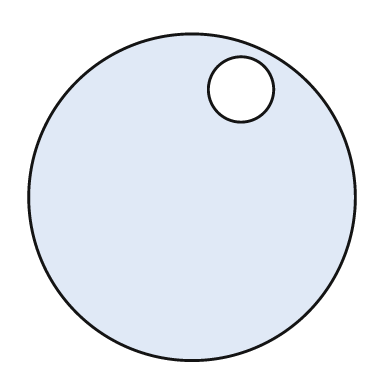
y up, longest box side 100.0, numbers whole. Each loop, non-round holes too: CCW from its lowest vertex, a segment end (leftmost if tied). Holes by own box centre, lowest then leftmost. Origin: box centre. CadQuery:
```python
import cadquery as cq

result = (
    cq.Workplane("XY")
    .moveTo(0.0, 0.0)
    .circle(50.0)
    .moveTo(15.0, 33.0)
    .circle(10.0)
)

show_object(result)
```